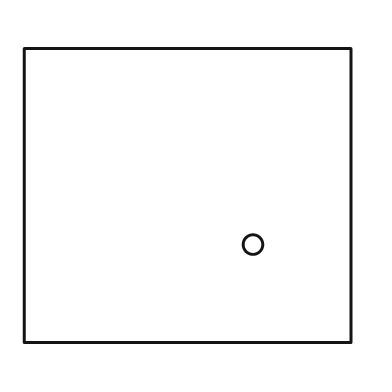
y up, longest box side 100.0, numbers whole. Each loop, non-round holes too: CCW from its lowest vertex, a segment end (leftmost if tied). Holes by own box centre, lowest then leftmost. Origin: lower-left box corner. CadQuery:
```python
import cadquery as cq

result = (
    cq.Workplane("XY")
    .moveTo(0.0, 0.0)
    .lineTo(100.0, 0.0)
    .lineTo(100.0, 90.0)
    .lineTo(0.0, 90.0)
    .close()
    .moveTo(70.0, 30.0)
    .circle(3.0)
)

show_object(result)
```